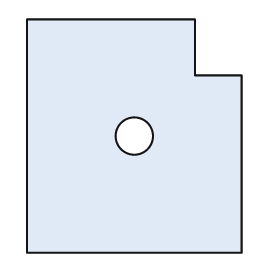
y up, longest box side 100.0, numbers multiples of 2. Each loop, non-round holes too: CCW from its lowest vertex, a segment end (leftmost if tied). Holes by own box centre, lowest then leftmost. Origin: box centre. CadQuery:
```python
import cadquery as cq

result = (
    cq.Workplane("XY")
    .moveTo(-46.0, -50.0)
    .lineTo(46.0, -50.0)
    .lineTo(46.0, 26.0)
    .lineTo(26.0, 26.0)
    .lineTo(26.0, 50.0)
    .lineTo(-46.0, 50.0)
    .close()
    .moveTo(0.0, 0.0)
    .circle(8.0)
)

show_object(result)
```